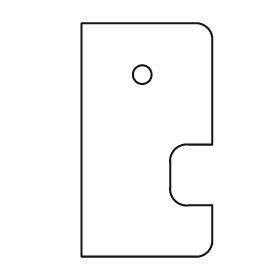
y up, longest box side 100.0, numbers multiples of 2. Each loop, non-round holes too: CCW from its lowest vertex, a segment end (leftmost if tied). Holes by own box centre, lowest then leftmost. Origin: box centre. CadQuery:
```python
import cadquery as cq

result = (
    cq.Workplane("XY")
    .moveTo(-28.0, -50.0)
    .lineTo(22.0, -50.0)
    .threePointArc((26.0, -48.0), (28.0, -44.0))
    .lineTo(28.0, -28.0)
    .lineTo(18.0, -28.0)
    .threePointArc((12.0, -26.0), (10.0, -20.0))
    .lineTo(10.0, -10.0)
    .threePointArc((12.0, -4.0), (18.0, -2.0))
    .lineTo(28.0, -2.0)
    .lineTo(28.0, 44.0)
    .threePointArc((26.0, 48.0), (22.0, 50.0))
    .lineTo(-28.0, 50.0)
    .close()
    .moveTo(-2.0, 28.0)
    .circle(4.0)
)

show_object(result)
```